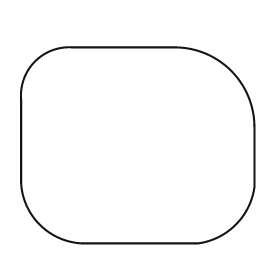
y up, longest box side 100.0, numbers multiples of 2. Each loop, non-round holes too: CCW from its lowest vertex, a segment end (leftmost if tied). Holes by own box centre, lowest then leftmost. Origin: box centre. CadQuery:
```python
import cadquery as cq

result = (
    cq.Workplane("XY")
    .moveTo(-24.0, -42.0)
    .lineTo(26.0, -42.0)
    .threePointArc((42.0, -34.0), (50.0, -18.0))
    .lineTo(50.0, 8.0)
    .threePointArc((40.0, 32.0), (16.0, 42.0))
    .lineTo(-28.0, 42.0)
    .threePointArc((-44.0, 36.0), (-50.0, 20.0))
    .lineTo(-50.0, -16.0)
    .threePointArc((-42.0, -34.0), (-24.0, -42.0))
    .close()
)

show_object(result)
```